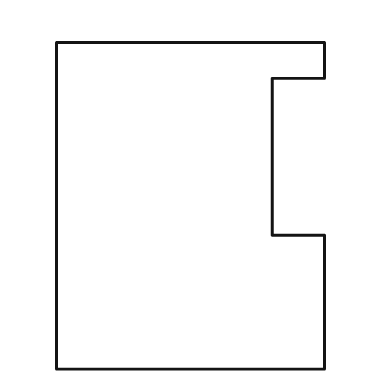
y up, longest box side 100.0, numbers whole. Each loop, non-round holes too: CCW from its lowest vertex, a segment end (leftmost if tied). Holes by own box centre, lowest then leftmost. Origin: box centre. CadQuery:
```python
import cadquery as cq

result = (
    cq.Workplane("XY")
    .moveTo(-41.0, -50.0)
    .lineTo(41.0, -50.0)
    .lineTo(41.0, -9.0)
    .lineTo(25.0, -9.0)
    .lineTo(25.0, 39.0)
    .lineTo(41.0, 39.0)
    .lineTo(41.0, 50.0)
    .lineTo(-41.0, 50.0)
    .close()
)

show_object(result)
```